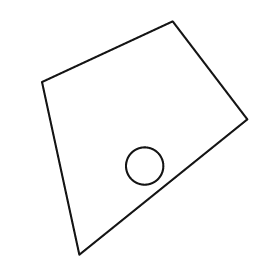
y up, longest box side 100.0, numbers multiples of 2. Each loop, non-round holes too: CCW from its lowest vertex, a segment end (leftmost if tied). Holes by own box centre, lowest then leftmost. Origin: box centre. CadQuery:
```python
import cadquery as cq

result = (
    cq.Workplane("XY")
    .moveTo(-28.0, -50.0)
    .lineTo(44.0, 8.0)
    .lineTo(12.0, 50.0)
    .lineTo(-44.0, 24.0)
    .close()
    .moveTo(0.0, -12.0)
    .circle(8.0)
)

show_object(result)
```